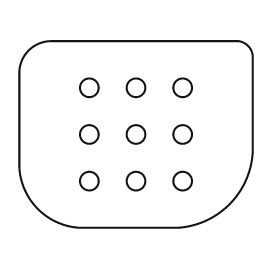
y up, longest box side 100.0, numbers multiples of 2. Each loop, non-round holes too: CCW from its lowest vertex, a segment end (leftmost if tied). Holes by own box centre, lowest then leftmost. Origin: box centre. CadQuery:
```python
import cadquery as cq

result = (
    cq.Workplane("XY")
    .moveTo(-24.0, -40.0)
    .lineTo(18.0, -40.0)
    .threePointArc((40.0, -30.0), (50.0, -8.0))
    .lineTo(50.0, 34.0)
    .threePointArc((48.0, 38.0), (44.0, 40.0))
    .lineTo(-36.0, 40.0)
    .threePointArc((-46.0, 36.0), (-50.0, 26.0))
    .lineTo(-50.0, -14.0)
    .threePointArc((-42.0, -32.0), (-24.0, -40.0))
    .close()
    .moveTo(-20.0, -20.0)
    .circle(4.0)
    .moveTo(0.0, -20.0)
    .circle(4.0)
    .moveTo(20.0, -20.0)
    .circle(4.0)
    .moveTo(-20.0, 0.0)
    .circle(4.0)
    .moveTo(0.0, 0.0)
    .circle(4.0)
    .moveTo(20.0, 0.0)
    .circle(4.0)
    .moveTo(-20.0, 20.0)
    .circle(4.0)
    .moveTo(0.0, 20.0)
    .circle(4.0)
    .moveTo(20.0, 20.0)
    .circle(4.0)
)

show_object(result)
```